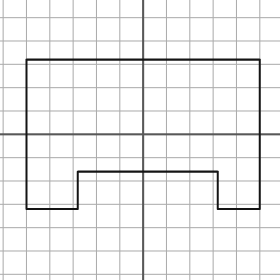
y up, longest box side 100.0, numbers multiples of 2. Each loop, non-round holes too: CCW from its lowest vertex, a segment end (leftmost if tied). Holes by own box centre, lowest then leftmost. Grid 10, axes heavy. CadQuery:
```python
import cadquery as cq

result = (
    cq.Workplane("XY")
    .moveTo(-50.0, -32.0)
    .lineTo(-28.0, -32.0)
    .lineTo(-28.0, -16.0)
    .lineTo(32.0, -16.0)
    .lineTo(32.0, -32.0)
    .lineTo(50.0, -32.0)
    .lineTo(50.0, 32.0)
    .lineTo(-50.0, 32.0)
    .close()
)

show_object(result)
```